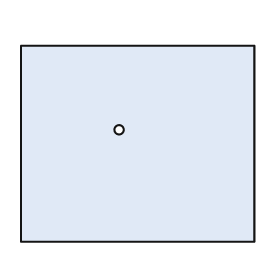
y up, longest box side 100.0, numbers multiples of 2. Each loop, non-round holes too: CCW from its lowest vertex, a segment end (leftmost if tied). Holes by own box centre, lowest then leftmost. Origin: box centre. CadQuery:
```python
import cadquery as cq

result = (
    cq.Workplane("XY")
    .moveTo(-50.0, -42.0)
    .lineTo(50.0, -42.0)
    .lineTo(50.0, 42.0)
    .lineTo(-50.0, 42.0)
    .close()
    .moveTo(-8.0, 6.0)
    .circle(2.0)
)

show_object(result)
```